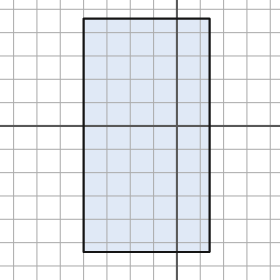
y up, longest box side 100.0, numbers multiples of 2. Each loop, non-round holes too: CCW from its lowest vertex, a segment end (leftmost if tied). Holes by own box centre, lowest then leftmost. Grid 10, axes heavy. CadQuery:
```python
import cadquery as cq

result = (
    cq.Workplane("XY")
    .moveTo(-40.0, -54.0)
    .lineTo(14.0, -54.0)
    .lineTo(14.0, 46.0)
    .lineTo(-40.0, 46.0)
    .close()
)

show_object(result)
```